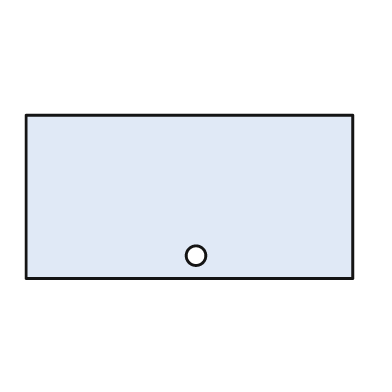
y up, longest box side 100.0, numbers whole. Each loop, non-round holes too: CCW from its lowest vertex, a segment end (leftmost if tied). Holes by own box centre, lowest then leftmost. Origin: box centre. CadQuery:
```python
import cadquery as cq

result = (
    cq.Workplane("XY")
    .moveTo(-50.0, -25.0)
    .lineTo(50.0, -25.0)
    .lineTo(50.0, 25.0)
    .lineTo(-50.0, 25.0)
    .close()
    .moveTo(2.0, -18.0)
    .circle(3.0)
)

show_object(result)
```